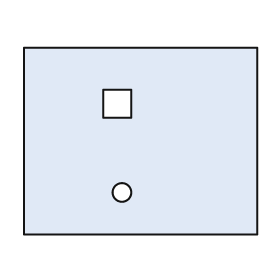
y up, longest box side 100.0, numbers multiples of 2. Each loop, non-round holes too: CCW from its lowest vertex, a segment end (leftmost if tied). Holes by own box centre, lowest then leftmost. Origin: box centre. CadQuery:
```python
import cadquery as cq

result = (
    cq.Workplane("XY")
    .moveTo(-50.0, -40.0)
    .lineTo(50.0, -40.0)
    .lineTo(50.0, 40.0)
    .lineTo(-50.0, 40.0)
    .close()
    .moveTo(-8.0, -22.0)
    .circle(4.0)
    .moveTo(-16.0, 10.0)
    .lineTo(-4.0, 10.0)
    .lineTo(-4.0, 22.0)
    .lineTo(-16.0, 22.0)
    .close()
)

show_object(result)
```